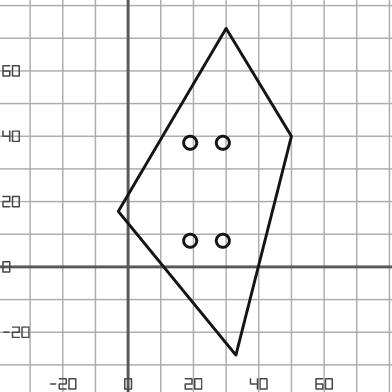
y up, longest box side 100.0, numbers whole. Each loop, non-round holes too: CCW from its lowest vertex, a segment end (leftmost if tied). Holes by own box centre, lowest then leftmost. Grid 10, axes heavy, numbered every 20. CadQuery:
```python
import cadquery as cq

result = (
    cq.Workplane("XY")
    .moveTo(33.0, -27.0)
    .lineTo(50.0, 40.0)
    .lineTo(30.0, 73.0)
    .lineTo(-3.0, 17.0)
    .close()
    .moveTo(19.0, 8.0)
    .circle(2.0)
    .moveTo(29.0, 8.0)
    .circle(2.0)
    .moveTo(19.0, 38.0)
    .circle(2.0)
    .moveTo(29.0, 38.0)
    .circle(2.0)
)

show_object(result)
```